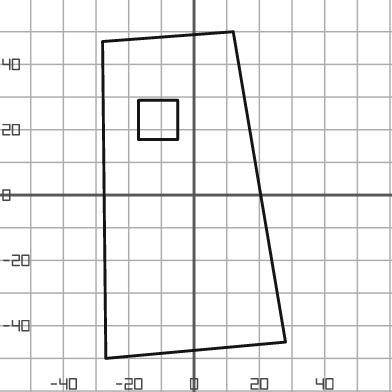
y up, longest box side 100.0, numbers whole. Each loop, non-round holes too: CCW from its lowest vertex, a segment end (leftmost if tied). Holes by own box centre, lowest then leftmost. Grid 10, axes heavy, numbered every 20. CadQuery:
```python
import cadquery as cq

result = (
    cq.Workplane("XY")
    .moveTo(-27.0, -50.0)
    .lineTo(28.0, -45.0)
    .lineTo(12.0, 50.0)
    .lineTo(-28.0, 47.0)
    .close()
    .moveTo(-17.0, 17.0)
    .lineTo(-5.0, 17.0)
    .lineTo(-5.0, 29.0)
    .lineTo(-17.0, 29.0)
    .close()
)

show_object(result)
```